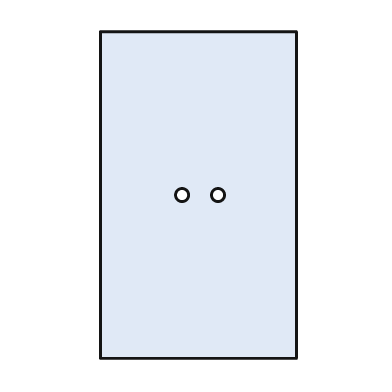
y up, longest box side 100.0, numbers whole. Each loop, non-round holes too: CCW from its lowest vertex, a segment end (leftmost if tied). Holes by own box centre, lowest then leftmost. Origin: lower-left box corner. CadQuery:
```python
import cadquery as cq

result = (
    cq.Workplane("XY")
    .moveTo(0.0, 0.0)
    .lineTo(60.0, 0.0)
    .lineTo(60.0, 100.0)
    .lineTo(0.0, 100.0)
    .close()
    .moveTo(25.0, 50.0)
    .circle(2.0)
    .moveTo(36.0, 50.0)
    .circle(2.0)
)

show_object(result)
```